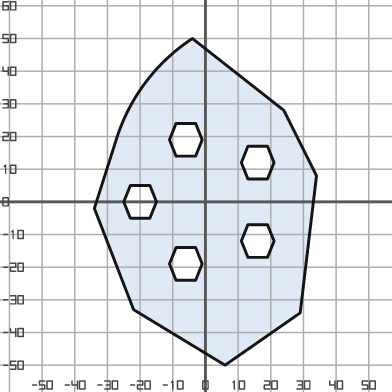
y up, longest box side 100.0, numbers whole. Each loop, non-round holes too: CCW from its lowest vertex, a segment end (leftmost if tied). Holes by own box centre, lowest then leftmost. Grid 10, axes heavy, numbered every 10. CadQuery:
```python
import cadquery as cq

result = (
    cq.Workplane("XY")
    .moveTo(6.0, -50.0)
    .lineTo(29.0, -34.0)
    .lineTo(34.0, 8.0)
    .lineTo(24.0, 28.0)
    .lineTo(-4.0, 50.0)
    .threePointArc((-18.0, 37.0), (-27.0, 20.0))
    .lineTo(-34.0, -2.0)
    .lineTo(-22.0, -33.0)
    .close()
    .moveTo(-9.0, -24.0)
    .lineTo(-3.0, -24.0)
    .lineTo(-1.0, -19.0)
    .lineTo(-3.0, -14.0)
    .lineTo(-9.0, -14.0)
    .lineTo(-11.0, -19.0)
    .close()
    .moveTo(13.0, -17.0)
    .lineTo(19.0, -17.0)
    .lineTo(21.0, -12.0)
    .lineTo(19.0, -7.0)
    .lineTo(13.0, -7.0)
    .lineTo(11.0, -12.0)
    .close()
    .moveTo(-23.0, -5.0)
    .lineTo(-17.0, -5.0)
    .lineTo(-15.0, 0.0)
    .lineTo(-17.0, 5.0)
    .lineTo(-23.0, 5.0)
    .lineTo(-25.0, 0.0)
    .close()
    .moveTo(13.0, 7.0)
    .lineTo(19.0, 7.0)
    .lineTo(21.0, 12.0)
    .lineTo(19.0, 17.0)
    .lineTo(13.0, 17.0)
    .lineTo(11.0, 12.0)
    .close()
    .moveTo(-9.0, 14.0)
    .lineTo(-3.0, 14.0)
    .lineTo(-1.0, 19.0)
    .lineTo(-3.0, 24.0)
    .lineTo(-9.0, 24.0)
    .lineTo(-11.0, 19.0)
    .close()
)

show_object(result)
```